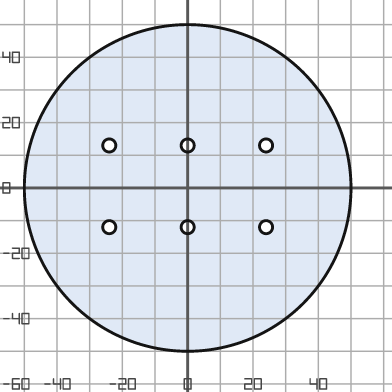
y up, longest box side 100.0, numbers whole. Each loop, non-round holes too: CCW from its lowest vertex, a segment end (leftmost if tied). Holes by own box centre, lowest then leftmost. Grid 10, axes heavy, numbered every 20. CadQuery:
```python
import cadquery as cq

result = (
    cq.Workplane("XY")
    .moveTo(0.0, 0.0)
    .circle(50.0)
    .moveTo(-24.0, -12.0)
    .circle(2.0)
    .moveTo(0.0, -12.0)
    .circle(2.0)
    .moveTo(24.0, -12.0)
    .circle(2.0)
    .moveTo(-24.0, 13.0)
    .circle(2.0)
    .moveTo(0.0, 13.0)
    .circle(2.0)
    .moveTo(24.0, 13.0)
    .circle(2.0)
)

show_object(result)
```